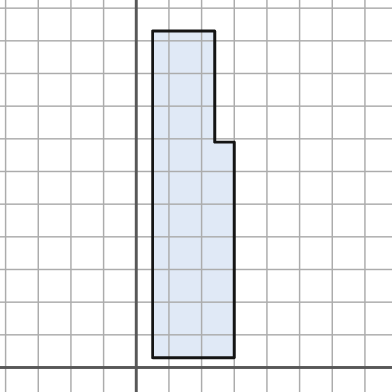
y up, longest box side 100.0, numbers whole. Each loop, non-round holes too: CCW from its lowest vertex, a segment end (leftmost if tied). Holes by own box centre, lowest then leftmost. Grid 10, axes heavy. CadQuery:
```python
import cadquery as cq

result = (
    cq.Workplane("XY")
    .moveTo(5.0, 3.0)
    .lineTo(30.0, 3.0)
    .lineTo(30.0, 69.0)
    .lineTo(24.0, 69.0)
    .lineTo(24.0, 103.0)
    .lineTo(5.0, 103.0)
    .close()
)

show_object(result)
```